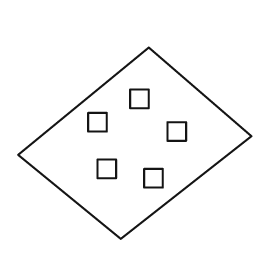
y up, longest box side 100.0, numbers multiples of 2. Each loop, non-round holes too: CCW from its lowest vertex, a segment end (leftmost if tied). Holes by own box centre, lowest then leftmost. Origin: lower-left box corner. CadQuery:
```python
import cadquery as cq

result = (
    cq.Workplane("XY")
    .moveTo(44.0, 0.0)
    .lineTo(100.0, 44.0)
    .lineTo(56.0, 82.0)
    .lineTo(0.0, 36.0)
    .close()
    .moveTo(54.0, 22.0)
    .lineTo(62.0, 22.0)
    .lineTo(62.0, 30.0)
    .lineTo(54.0, 30.0)
    .close()
    .moveTo(34.0, 26.0)
    .lineTo(42.0, 26.0)
    .lineTo(42.0, 34.0)
    .lineTo(34.0, 34.0)
    .close()
    .moveTo(64.0, 42.0)
    .lineTo(72.0, 42.0)
    .lineTo(72.0, 50.0)
    .lineTo(64.0, 50.0)
    .close()
    .moveTo(30.0, 46.0)
    .lineTo(38.0, 46.0)
    .lineTo(38.0, 54.0)
    .lineTo(30.0, 54.0)
    .close()
    .moveTo(48.0, 56.0)
    .lineTo(56.0, 56.0)
    .lineTo(56.0, 64.0)
    .lineTo(48.0, 64.0)
    .close()
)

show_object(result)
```